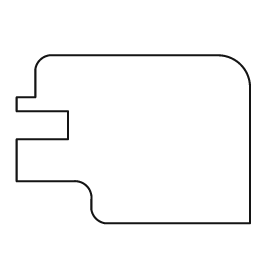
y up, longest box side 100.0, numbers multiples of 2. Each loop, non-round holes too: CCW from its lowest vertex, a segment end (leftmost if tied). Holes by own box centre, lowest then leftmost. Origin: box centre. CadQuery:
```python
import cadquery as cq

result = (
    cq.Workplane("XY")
    .moveTo(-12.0, -36.0)
    .lineTo(50.0, -36.0)
    .lineTo(50.0, 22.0)
    .threePointArc((46.0, 32.0), (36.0, 36.0))
    .lineTo(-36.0, 36.0)
    .threePointArc((-40.0, 34.0), (-42.0, 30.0))
    .lineTo(-42.0, 18.0)
    .lineTo(-50.0, 18.0)
    .lineTo(-50.0, 12.0)
    .lineTo(-28.0, 12.0)
    .lineTo(-28.0, 0.0)
    .lineTo(-50.0, 0.0)
    .lineTo(-50.0, -18.0)
    .lineTo(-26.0, -18.0)
    .threePointArc((-20.0, -20.0), (-18.0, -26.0))
    .lineTo(-18.0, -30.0)
    .threePointArc((-16.0, -34.0), (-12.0, -36.0))
    .close()
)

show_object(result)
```